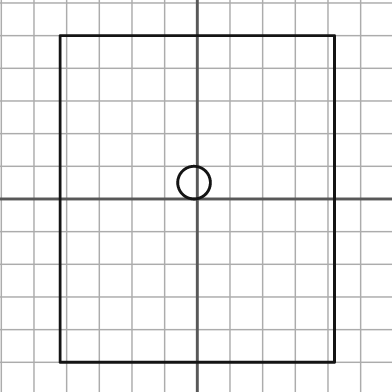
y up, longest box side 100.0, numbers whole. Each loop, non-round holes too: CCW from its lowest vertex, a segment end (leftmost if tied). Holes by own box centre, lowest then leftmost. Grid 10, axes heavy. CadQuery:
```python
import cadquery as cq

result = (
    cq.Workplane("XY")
    .moveTo(-42.0, -50.0)
    .lineTo(42.0, -50.0)
    .lineTo(42.0, 50.0)
    .lineTo(-42.0, 50.0)
    .close()
    .moveTo(-1.0, 5.0)
    .circle(5.0)
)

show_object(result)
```